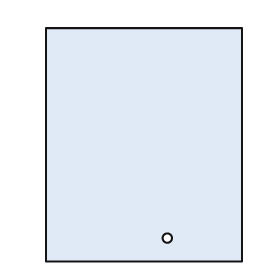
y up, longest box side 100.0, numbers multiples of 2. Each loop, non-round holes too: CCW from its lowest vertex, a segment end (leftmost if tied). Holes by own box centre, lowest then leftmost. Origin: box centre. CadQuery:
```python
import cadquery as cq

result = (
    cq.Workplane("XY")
    .moveTo(-42.0, -50.0)
    .lineTo(42.0, -50.0)
    .lineTo(42.0, 50.0)
    .lineTo(-42.0, 50.0)
    .close()
    .moveTo(10.0, -40.0)
    .circle(2.0)
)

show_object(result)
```